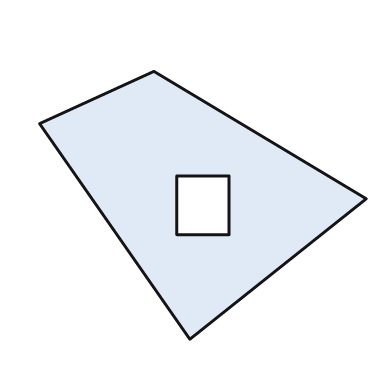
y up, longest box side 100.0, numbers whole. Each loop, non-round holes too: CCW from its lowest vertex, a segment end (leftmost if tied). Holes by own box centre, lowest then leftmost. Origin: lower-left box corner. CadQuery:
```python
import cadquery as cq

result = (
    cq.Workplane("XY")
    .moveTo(46.0, 0.0)
    .lineTo(100.0, 43.0)
    .lineTo(35.0, 82.0)
    .lineTo(0.0, 66.0)
    .close()
    .moveTo(42.0, 32.0)
    .lineTo(58.0, 32.0)
    .lineTo(58.0, 50.0)
    .lineTo(42.0, 50.0)
    .close()
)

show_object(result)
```